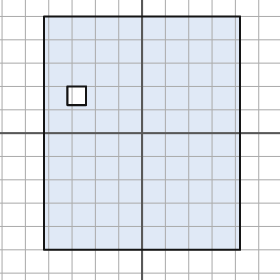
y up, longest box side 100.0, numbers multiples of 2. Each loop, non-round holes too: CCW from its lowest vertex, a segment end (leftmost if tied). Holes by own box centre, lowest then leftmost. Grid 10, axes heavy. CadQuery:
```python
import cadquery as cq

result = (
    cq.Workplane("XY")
    .moveTo(-42.0, -50.0)
    .lineTo(42.0, -50.0)
    .lineTo(42.0, 50.0)
    .lineTo(-42.0, 50.0)
    .close()
    .moveTo(-32.0, 12.0)
    .lineTo(-24.0, 12.0)
    .lineTo(-24.0, 20.0)
    .lineTo(-32.0, 20.0)
    .close()
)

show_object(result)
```